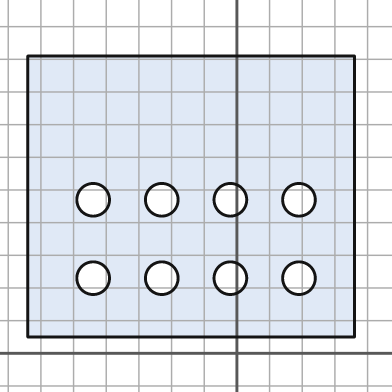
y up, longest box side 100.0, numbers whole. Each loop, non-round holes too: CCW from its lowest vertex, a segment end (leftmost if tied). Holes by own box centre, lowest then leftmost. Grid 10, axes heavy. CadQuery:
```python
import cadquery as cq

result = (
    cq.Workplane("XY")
    .moveTo(-64.0, 5.0)
    .lineTo(36.0, 5.0)
    .lineTo(36.0, 91.0)
    .lineTo(-64.0, 91.0)
    .close()
    .moveTo(-44.0, 23.0)
    .circle(5.0)
    .moveTo(-23.0, 23.0)
    .circle(5.0)
    .moveTo(-2.0, 23.0)
    .circle(5.0)
    .moveTo(19.0, 23.0)
    .circle(5.0)
    .moveTo(-44.0, 47.0)
    .circle(5.0)
    .moveTo(-23.0, 47.0)
    .circle(5.0)
    .moveTo(-2.0, 47.0)
    .circle(5.0)
    .moveTo(19.0, 47.0)
    .circle(5.0)
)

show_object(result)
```